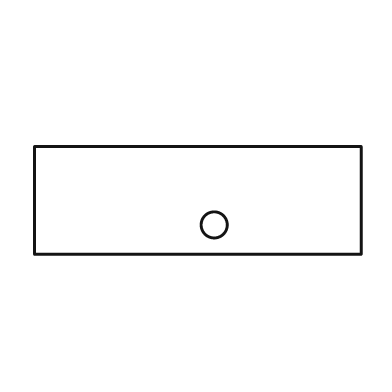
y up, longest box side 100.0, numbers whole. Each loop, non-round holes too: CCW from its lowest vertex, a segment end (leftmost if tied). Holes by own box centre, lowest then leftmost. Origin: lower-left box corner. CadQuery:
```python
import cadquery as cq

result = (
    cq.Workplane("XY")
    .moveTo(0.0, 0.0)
    .lineTo(100.0, 0.0)
    .lineTo(100.0, 33.0)
    .lineTo(0.0, 33.0)
    .close()
    .moveTo(55.0, 9.0)
    .circle(4.0)
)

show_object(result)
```